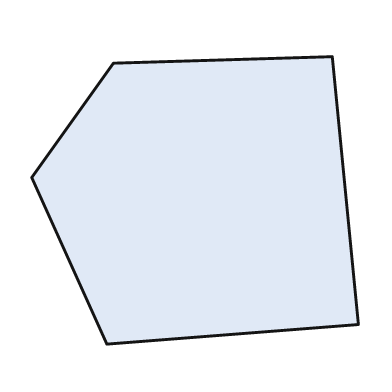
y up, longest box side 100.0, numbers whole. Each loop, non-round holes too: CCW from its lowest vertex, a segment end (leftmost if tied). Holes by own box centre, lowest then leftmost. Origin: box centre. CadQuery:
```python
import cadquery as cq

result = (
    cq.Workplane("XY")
    .moveTo(-27.0, -44.0)
    .lineTo(50.0, -38.0)
    .lineTo(42.0, 44.0)
    .lineTo(-25.0, 42.0)
    .lineTo(-50.0, 7.0)
    .close()
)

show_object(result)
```